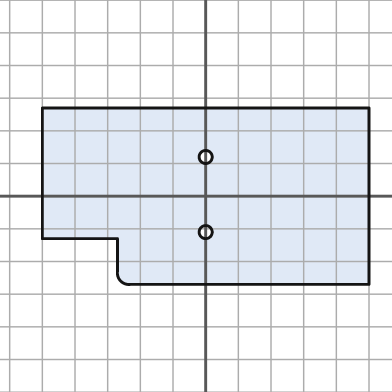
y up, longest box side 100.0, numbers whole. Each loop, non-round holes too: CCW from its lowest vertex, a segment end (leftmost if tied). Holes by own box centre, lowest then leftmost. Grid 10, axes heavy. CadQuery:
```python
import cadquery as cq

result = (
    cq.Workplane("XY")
    .moveTo(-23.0, -27.0)
    .lineTo(50.0, -27.0)
    .lineTo(50.0, 27.0)
    .lineTo(-50.0, 27.0)
    .lineTo(-50.0, -13.0)
    .lineTo(-27.0, -13.0)
    .lineTo(-27.0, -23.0)
    .threePointArc((-26.0, -26.0), (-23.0, -27.0))
    .close()
    .moveTo(0.0, -11.0)
    .circle(2.0)
    .moveTo(0.0, 12.0)
    .circle(2.0)
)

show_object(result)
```